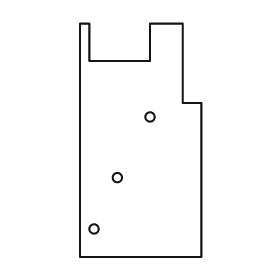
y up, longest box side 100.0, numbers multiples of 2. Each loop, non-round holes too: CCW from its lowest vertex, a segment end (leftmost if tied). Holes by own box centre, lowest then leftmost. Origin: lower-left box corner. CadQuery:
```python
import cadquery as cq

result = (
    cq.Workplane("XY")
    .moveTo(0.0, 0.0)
    .lineTo(52.0, 0.0)
    .lineTo(52.0, 66.0)
    .lineTo(44.0, 66.0)
    .lineTo(44.0, 100.0)
    .lineTo(30.0, 100.0)
    .lineTo(30.0, 84.0)
    .lineTo(4.0, 84.0)
    .lineTo(4.0, 100.0)
    .lineTo(0.0, 100.0)
    .close()
    .moveTo(6.0, 12.0)
    .circle(2.0)
    .moveTo(16.0, 34.0)
    .circle(2.0)
    .moveTo(30.0, 60.0)
    .circle(2.0)
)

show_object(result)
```